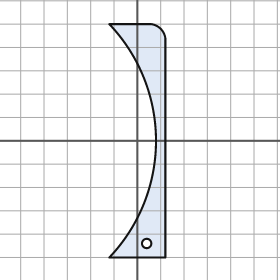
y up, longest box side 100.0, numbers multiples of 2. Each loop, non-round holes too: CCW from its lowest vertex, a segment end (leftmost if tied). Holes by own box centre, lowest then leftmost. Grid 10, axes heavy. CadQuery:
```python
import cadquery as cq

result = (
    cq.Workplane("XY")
    .moveTo(-12.0, -50.0)
    .lineTo(12.0, -50.0)
    .lineTo(12.0, 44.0)
    .threePointArc((10.0, 48.0), (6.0, 50.0))
    .lineTo(-12.0, 50.0)
    .threePointArc((8.0, 0.0), (-12.0, -50.0))
    .close()
    .moveTo(4.0, -44.0)
    .circle(2.0)
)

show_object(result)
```